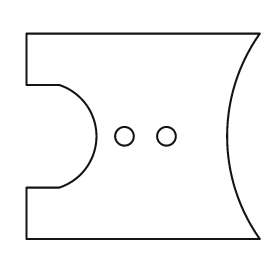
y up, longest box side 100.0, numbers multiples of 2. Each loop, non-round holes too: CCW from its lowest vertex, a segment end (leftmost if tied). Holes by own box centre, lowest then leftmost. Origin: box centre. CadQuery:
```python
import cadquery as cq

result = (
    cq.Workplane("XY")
    .moveTo(-50.0, -44.0)
    .lineTo(50.0, -44.0)
    .threePointArc((36.0, 0.0), (50.0, 44.0))
    .lineTo(-50.0, 44.0)
    .lineTo(-50.0, 22.0)
    .lineTo(-36.0, 22.0)
    .threePointArc((-20.0, 0.0), (-36.0, -22.0))
    .lineTo(-50.0, -22.0)
    .close()
    .moveTo(-8.0, 0.0)
    .circle(4.0)
    .moveTo(10.0, 0.0)
    .circle(4.0)
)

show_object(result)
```